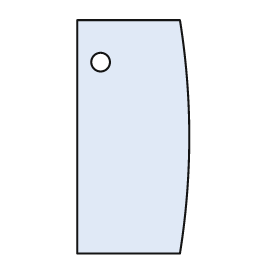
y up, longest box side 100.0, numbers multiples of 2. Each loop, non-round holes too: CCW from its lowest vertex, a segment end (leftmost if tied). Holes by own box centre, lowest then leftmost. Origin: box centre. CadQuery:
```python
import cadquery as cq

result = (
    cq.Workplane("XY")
    .moveTo(-24.0, -50.0)
    .lineTo(20.0, -50.0)
    .threePointArc((24.0, 0.0), (20.0, 50.0))
    .lineTo(-24.0, 50.0)
    .close()
    .moveTo(-14.0, 32.0)
    .circle(4.0)
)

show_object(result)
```